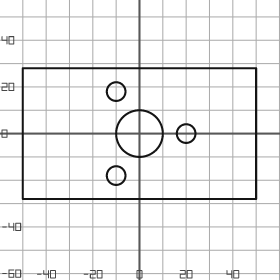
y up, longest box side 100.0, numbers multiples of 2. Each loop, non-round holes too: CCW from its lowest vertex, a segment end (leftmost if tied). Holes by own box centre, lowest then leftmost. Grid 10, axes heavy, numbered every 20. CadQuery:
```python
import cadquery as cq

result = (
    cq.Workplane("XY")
    .moveTo(-50.0, -28.0)
    .lineTo(50.0, -28.0)
    .lineTo(50.0, 28.0)
    .lineTo(-50.0, 28.0)
    .close()
    .moveTo(-10.0, -18.0)
    .circle(4.0)
    .moveTo(0.0, 0.0)
    .circle(10.0)
    .moveTo(20.0, 0.0)
    .circle(4.0)
    .moveTo(-10.0, 18.0)
    .circle(4.0)
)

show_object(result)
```